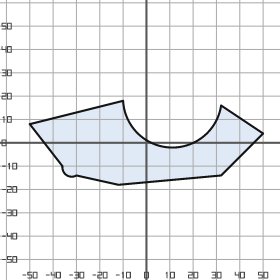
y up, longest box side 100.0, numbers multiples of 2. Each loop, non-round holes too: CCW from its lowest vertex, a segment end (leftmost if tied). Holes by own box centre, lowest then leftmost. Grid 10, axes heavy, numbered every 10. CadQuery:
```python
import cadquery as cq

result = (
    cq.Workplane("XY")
    .moveTo(-12.0, -18.0)
    .lineTo(32.0, -14.0)
    .lineTo(50.0, 4.0)
    .lineTo(32.0, 16.0)
    .threePointArc((10.0, -2.0), (-10.0, 18.0))
    .lineTo(-50.0, 8.0)
    .lineTo(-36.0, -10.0)
    .threePointArc((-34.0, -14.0), (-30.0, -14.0))
    .close()
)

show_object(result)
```